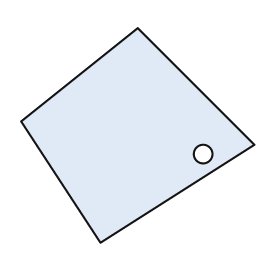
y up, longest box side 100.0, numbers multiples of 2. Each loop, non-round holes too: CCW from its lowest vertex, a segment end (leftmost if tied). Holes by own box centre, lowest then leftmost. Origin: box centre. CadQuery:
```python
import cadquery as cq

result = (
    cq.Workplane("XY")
    .moveTo(-16.0, -46.0)
    .lineTo(50.0, -4.0)
    .lineTo(0.0, 46.0)
    .lineTo(-50.0, 6.0)
    .close()
    .moveTo(28.0, -8.0)
    .circle(4.0)
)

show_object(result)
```